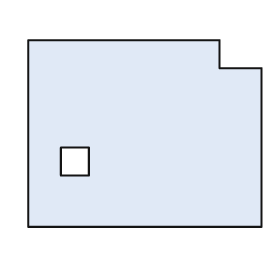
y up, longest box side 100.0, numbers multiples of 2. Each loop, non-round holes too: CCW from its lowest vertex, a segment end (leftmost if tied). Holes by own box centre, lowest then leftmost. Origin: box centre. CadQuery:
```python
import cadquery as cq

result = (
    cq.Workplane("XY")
    .moveTo(-50.0, -40.0)
    .lineTo(50.0, -40.0)
    .lineTo(50.0, 28.0)
    .lineTo(32.0, 28.0)
    .lineTo(32.0, 40.0)
    .lineTo(-50.0, 40.0)
    .close()
    .moveTo(-36.0, -18.0)
    .lineTo(-24.0, -18.0)
    .lineTo(-24.0, -6.0)
    .lineTo(-36.0, -6.0)
    .close()
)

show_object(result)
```